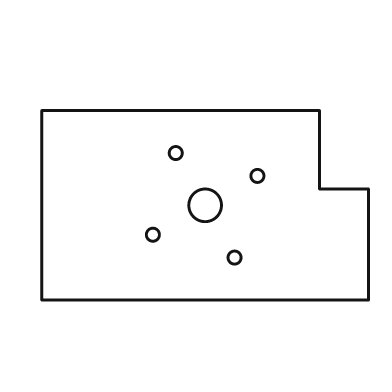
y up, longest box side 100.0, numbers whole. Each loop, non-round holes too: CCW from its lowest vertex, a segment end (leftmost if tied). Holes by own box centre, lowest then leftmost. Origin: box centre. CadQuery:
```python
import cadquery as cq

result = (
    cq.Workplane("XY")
    .moveTo(-50.0, -29.0)
    .lineTo(50.0, -29.0)
    .lineTo(50.0, 5.0)
    .lineTo(35.0, 5.0)
    .lineTo(35.0, 29.0)
    .lineTo(-50.0, 29.0)
    .close()
    .moveTo(9.0, -16.0)
    .circle(2.0)
    .moveTo(-16.0, -9.0)
    .circle(2.0)
    .moveTo(0.0, 0.0)
    .circle(5.0)
    .moveTo(16.0, 9.0)
    .circle(2.0)
    .moveTo(-9.0, 16.0)
    .circle(2.0)
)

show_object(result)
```